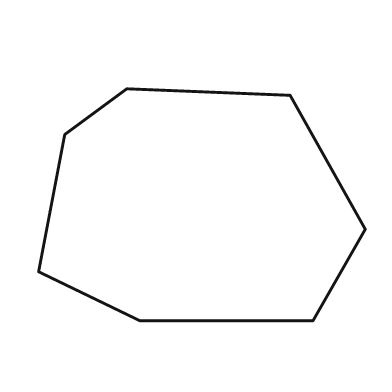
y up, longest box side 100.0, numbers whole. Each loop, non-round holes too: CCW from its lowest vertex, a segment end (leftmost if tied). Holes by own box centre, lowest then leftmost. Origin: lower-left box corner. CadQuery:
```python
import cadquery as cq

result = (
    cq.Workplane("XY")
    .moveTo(31.0, 0.0)
    .lineTo(84.0, 0.0)
    .lineTo(100.0, 28.0)
    .lineTo(77.0, 69.0)
    .lineTo(27.0, 71.0)
    .lineTo(8.0, 57.0)
    .lineTo(0.0, 15.0)
    .close()
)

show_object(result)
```